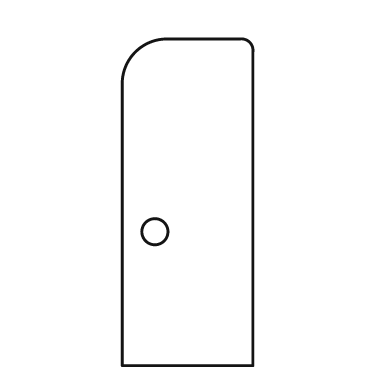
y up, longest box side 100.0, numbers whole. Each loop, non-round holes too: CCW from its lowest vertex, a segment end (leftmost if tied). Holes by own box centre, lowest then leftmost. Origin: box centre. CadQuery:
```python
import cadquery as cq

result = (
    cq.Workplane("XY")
    .moveTo(-20.0, -50.0)
    .lineTo(20.0, -50.0)
    .lineTo(20.0, 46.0)
    .threePointArc((19.0, 49.0), (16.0, 50.0))
    .lineTo(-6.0, 50.0)
    .threePointArc((-16.0, 46.0), (-20.0, 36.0))
    .close()
    .moveTo(-10.0, -9.0)
    .circle(4.0)
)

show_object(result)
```